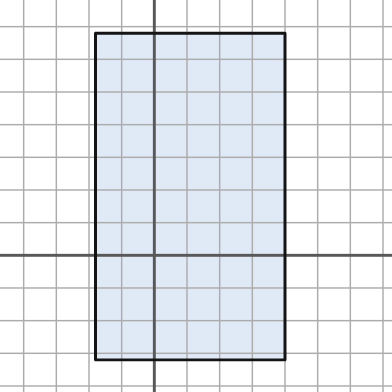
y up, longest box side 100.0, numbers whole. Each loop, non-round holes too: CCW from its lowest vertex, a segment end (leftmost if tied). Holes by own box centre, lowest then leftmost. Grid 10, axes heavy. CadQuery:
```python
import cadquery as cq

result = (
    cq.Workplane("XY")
    .moveTo(-18.0, -32.0)
    .lineTo(40.0, -32.0)
    .lineTo(40.0, 68.0)
    .lineTo(-18.0, 68.0)
    .close()
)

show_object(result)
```